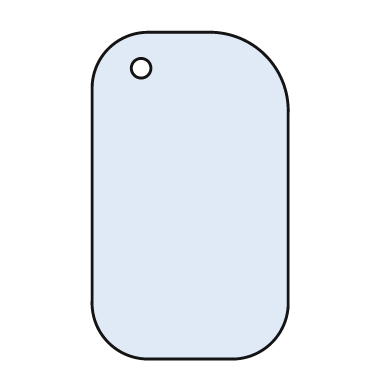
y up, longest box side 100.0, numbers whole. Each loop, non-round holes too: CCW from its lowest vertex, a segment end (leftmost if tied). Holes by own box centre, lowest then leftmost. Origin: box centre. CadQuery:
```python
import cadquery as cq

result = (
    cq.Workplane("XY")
    .moveTo(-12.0, -50.0)
    .lineTo(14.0, -50.0)
    .threePointArc((25.0, -45.0), (30.0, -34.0))
    .lineTo(30.0, 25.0)
    .threePointArc((23.0, 43.0), (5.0, 50.0))
    .lineTo(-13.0, 50.0)
    .threePointArc((-25.0, 45.0), (-30.0, 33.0))
    .lineTo(-30.0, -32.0)
    .threePointArc((-25.0, -45.0), (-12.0, -50.0))
    .close()
    .moveTo(-15.0, 39.0)
    .circle(3.0)
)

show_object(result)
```